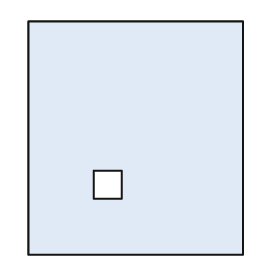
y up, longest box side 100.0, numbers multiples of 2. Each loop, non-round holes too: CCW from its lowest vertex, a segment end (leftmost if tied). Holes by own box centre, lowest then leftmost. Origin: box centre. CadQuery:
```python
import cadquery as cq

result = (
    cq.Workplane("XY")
    .moveTo(-46.0, -50.0)
    .lineTo(46.0, -50.0)
    .lineTo(46.0, 50.0)
    .lineTo(-46.0, 50.0)
    .close()
    .moveTo(-18.0, -26.0)
    .lineTo(-6.0, -26.0)
    .lineTo(-6.0, -14.0)
    .lineTo(-18.0, -14.0)
    .close()
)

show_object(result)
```